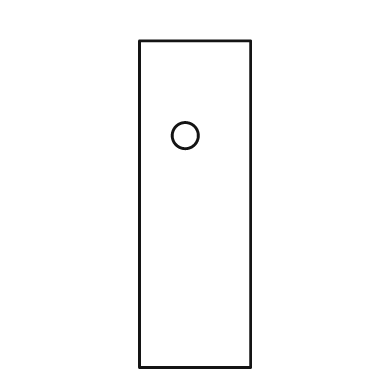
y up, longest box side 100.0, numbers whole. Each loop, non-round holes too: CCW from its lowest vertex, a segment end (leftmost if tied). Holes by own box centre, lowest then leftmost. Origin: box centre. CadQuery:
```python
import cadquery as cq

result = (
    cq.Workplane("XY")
    .moveTo(-17.0, -50.0)
    .lineTo(17.0, -50.0)
    .lineTo(17.0, 50.0)
    .lineTo(-17.0, 50.0)
    .close()
    .moveTo(-3.0, 21.0)
    .circle(4.0)
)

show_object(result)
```